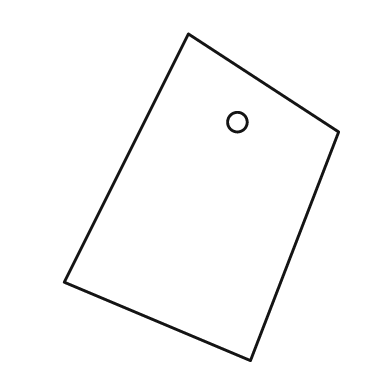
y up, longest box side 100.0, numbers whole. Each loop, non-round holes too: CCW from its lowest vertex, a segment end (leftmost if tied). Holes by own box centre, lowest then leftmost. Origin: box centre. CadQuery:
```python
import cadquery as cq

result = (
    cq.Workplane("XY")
    .moveTo(15.0, -50.0)
    .lineTo(42.0, 20.0)
    .lineTo(-4.0, 50.0)
    .lineTo(-42.0, -26.0)
    .close()
    .moveTo(11.0, 23.0)
    .circle(3.0)
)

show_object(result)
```